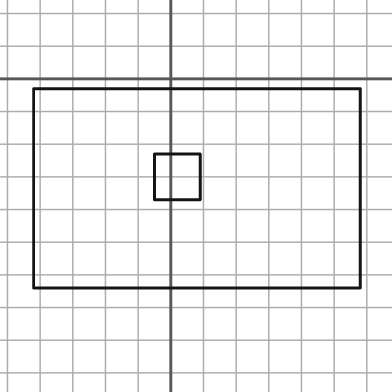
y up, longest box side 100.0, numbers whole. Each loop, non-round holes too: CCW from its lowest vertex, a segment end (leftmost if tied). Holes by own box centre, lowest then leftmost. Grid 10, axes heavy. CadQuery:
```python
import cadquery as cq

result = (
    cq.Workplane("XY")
    .moveTo(-42.0, -64.0)
    .lineTo(58.0, -64.0)
    .lineTo(58.0, -3.0)
    .lineTo(-42.0, -3.0)
    .close()
    .moveTo(-5.0, -37.0)
    .lineTo(9.0, -37.0)
    .lineTo(9.0, -23.0)
    .lineTo(-5.0, -23.0)
    .close()
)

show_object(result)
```